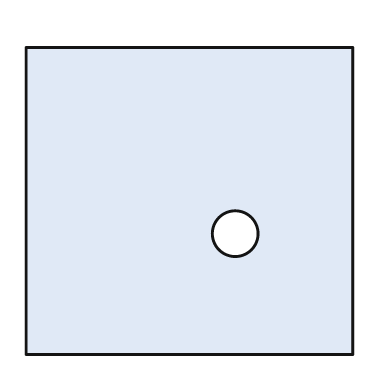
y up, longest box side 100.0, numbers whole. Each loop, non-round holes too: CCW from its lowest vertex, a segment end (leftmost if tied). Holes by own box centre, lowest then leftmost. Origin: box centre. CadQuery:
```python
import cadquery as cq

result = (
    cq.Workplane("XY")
    .moveTo(-50.0, -47.0)
    .lineTo(50.0, -47.0)
    .lineTo(50.0, 47.0)
    .lineTo(-50.0, 47.0)
    .close()
    .moveTo(14.0, -10.0)
    .circle(7.0)
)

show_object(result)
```